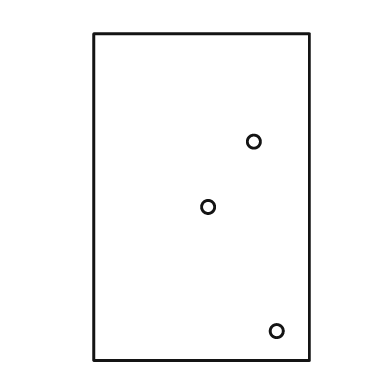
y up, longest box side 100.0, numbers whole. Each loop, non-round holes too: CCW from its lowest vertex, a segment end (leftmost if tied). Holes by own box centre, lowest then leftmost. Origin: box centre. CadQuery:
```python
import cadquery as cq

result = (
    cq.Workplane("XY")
    .moveTo(-33.0, -50.0)
    .lineTo(33.0, -50.0)
    .lineTo(33.0, 50.0)
    .lineTo(-33.0, 50.0)
    .close()
    .moveTo(23.0, -41.0)
    .circle(2.0)
    .moveTo(2.0, -3.0)
    .circle(2.0)
    .moveTo(16.0, 17.0)
    .circle(2.0)
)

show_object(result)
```